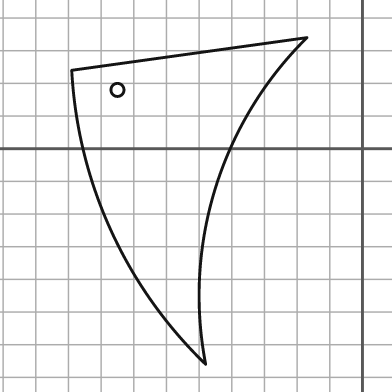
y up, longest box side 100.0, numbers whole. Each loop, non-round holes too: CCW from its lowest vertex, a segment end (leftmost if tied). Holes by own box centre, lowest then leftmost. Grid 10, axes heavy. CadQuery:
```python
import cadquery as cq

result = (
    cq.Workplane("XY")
    .moveTo(-48.0, -66.0)
    .threePointArc((-45.0, -12.0), (-17.0, 34.0))
    .lineTo(-89.0, 24.0)
    .threePointArc((-77.0, -25.0), (-48.0, -66.0))
    .close()
    .moveTo(-75.0, 18.0)
    .circle(2.0)
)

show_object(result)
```